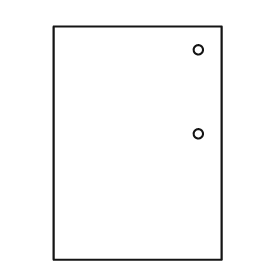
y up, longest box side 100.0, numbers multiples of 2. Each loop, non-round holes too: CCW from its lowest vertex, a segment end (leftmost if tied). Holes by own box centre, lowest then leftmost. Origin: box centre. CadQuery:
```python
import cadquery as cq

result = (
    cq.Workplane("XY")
    .moveTo(-36.0, -50.0)
    .lineTo(36.0, -50.0)
    .lineTo(36.0, 50.0)
    .lineTo(-36.0, 50.0)
    .close()
    .moveTo(26.0, 4.0)
    .circle(2.0)
    .moveTo(26.0, 40.0)
    .circle(2.0)
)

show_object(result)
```